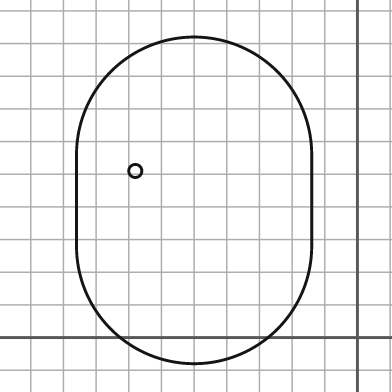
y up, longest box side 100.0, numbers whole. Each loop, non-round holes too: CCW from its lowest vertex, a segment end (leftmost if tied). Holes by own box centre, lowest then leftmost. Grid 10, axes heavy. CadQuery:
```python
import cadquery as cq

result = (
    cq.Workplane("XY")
    .moveTo(-86.0, 28.0)
    .threePointArc((-50.0, -8.0), (-14.0, 28.0))
    .lineTo(-14.0, 56.0)
    .threePointArc((-50.0, 92.0), (-86.0, 56.0))
    .close()
    .moveTo(-68.0, 51.0)
    .circle(2.0)
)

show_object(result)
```